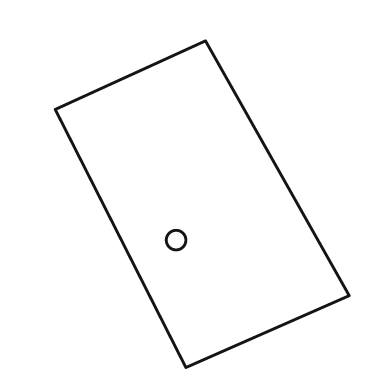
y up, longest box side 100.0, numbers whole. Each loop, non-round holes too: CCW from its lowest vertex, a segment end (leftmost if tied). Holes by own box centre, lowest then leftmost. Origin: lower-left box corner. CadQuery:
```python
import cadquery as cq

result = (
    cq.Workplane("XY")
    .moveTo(40.0, 0.0)
    .lineTo(90.0, 22.0)
    .lineTo(46.0, 100.0)
    .lineTo(0.0, 79.0)
    .close()
    .moveTo(37.0, 39.0)
    .circle(3.0)
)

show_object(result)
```